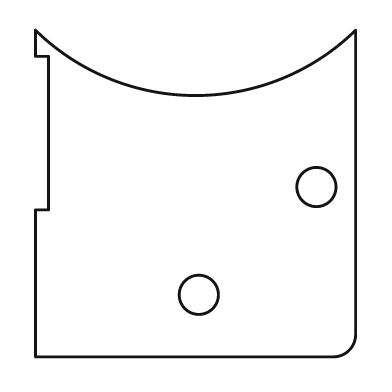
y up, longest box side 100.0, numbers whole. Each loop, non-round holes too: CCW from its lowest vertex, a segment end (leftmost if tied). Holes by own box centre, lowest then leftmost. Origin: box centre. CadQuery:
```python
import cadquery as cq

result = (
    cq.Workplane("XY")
    .moveTo(-49.0, -50.0)
    .lineTo(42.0, -50.0)
    .threePointArc((47.0, -48.0), (49.0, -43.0))
    .lineTo(49.0, 50.0)
    .threePointArc((0.0, 30.0), (-49.0, 50.0))
    .lineTo(-49.0, 42.0)
    .lineTo(-45.0, 42.0)
    .lineTo(-45.0, -5.0)
    .lineTo(-49.0, -5.0)
    .close()
    .moveTo(1.0, -31.0)
    .circle(6.0)
    .moveTo(37.0, 2.0)
    .circle(6.0)
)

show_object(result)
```